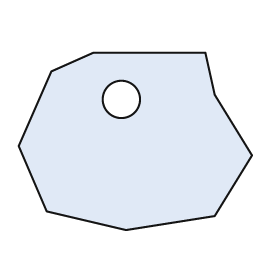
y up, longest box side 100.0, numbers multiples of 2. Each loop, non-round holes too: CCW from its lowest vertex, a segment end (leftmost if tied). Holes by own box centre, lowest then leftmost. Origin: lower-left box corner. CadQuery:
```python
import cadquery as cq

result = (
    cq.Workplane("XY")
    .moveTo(46.0, 0.0)
    .lineTo(84.0, 6.0)
    .lineTo(100.0, 32.0)
    .lineTo(84.0, 58.0)
    .lineTo(80.0, 76.0)
    .lineTo(32.0, 76.0)
    .lineTo(14.0, 68.0)
    .lineTo(0.0, 36.0)
    .lineTo(12.0, 8.0)
    .close()
    .moveTo(44.0, 56.0)
    .circle(8.0)
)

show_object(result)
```